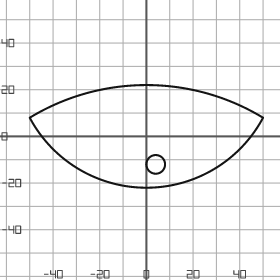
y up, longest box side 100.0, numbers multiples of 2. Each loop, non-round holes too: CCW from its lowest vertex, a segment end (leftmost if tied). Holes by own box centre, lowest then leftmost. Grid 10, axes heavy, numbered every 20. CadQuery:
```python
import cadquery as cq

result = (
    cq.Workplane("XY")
    .moveTo(-50.0, 8.0)
    .threePointArc((0.0, -22.0), (50.0, 8.0))
    .threePointArc((0.0, 22.0), (-50.0, 8.0))
    .close()
    .moveTo(4.0, -12.0)
    .circle(4.0)
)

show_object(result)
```